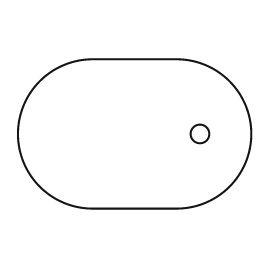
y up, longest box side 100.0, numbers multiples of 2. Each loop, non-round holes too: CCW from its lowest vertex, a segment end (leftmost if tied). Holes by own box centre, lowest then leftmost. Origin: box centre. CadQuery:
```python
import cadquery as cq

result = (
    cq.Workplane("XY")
    .moveTo(-18.0, -32.0)
    .lineTo(18.0, -32.0)
    .threePointArc((50.0, 0.0), (18.0, 32.0))
    .lineTo(-18.0, 32.0)
    .threePointArc((-50.0, 0.0), (-18.0, -32.0))
    .close()
    .moveTo(28.0, 0.0)
    .circle(4.0)
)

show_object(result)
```